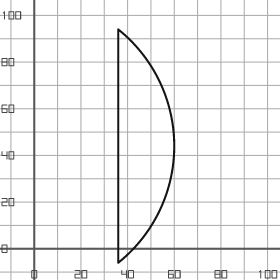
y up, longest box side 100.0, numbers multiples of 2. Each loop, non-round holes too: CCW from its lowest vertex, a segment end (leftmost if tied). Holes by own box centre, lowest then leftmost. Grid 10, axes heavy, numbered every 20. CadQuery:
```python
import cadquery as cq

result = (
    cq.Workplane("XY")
    .moveTo(36.0, -6.0)
    .threePointArc((60.0, 44.0), (36.0, 94.0))
    .close()
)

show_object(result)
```